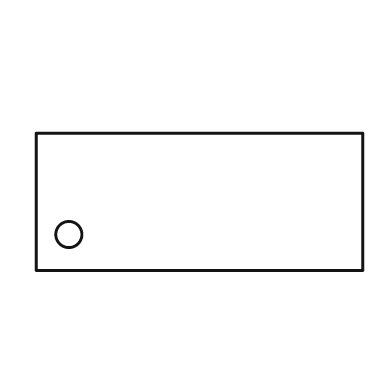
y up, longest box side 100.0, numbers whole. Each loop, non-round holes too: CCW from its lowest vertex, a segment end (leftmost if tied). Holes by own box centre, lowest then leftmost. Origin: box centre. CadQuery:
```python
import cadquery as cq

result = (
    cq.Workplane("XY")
    .moveTo(-50.0, -21.0)
    .lineTo(50.0, -21.0)
    .lineTo(50.0, 21.0)
    .lineTo(-50.0, 21.0)
    .close()
    .moveTo(-40.0, -10.0)
    .circle(4.0)
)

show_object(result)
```